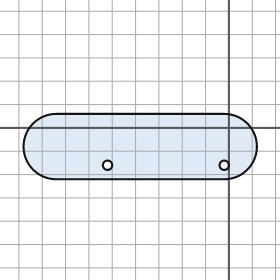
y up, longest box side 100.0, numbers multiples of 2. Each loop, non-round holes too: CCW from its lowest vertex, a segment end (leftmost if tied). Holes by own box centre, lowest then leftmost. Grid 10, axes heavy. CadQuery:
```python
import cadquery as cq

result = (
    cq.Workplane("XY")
    .moveTo(-74.0, -22.0)
    .lineTo(-2.0, -22.0)
    .threePointArc((12.0, -8.0), (-2.0, 6.0))
    .lineTo(-74.0, 6.0)
    .threePointArc((-88.0, -8.0), (-74.0, -22.0))
    .close()
    .moveTo(-52.0, -16.0)
    .circle(2.0)
    .moveTo(-2.0, -16.0)
    .circle(2.0)
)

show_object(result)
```